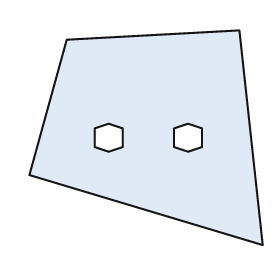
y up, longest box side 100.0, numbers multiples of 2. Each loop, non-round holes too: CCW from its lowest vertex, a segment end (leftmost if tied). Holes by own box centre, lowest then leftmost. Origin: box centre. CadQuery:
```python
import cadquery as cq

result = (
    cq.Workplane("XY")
    .moveTo(50.0, -46.0)
    .lineTo(40.0, 46.0)
    .lineTo(-34.0, 42.0)
    .lineTo(-50.0, -16.0)
    .close()
    .moveTo(-16.0, -6.0)
    .lineTo(-10.0, -4.0)
    .lineTo(-10.0, 4.0)
    .lineTo(-16.0, 6.0)
    .lineTo(-22.0, 4.0)
    .lineTo(-22.0, -4.0)
    .close()
    .moveTo(18.0, -6.0)
    .lineTo(24.0, -4.0)
    .lineTo(24.0, 4.0)
    .lineTo(18.0, 6.0)
    .lineTo(12.0, 4.0)
    .lineTo(12.0, -4.0)
    .close()
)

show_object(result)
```